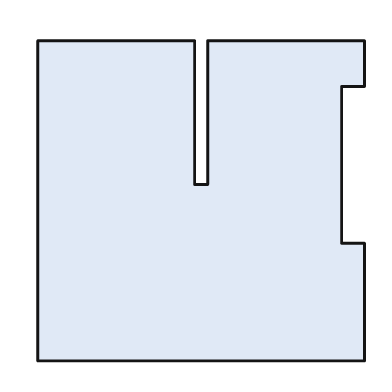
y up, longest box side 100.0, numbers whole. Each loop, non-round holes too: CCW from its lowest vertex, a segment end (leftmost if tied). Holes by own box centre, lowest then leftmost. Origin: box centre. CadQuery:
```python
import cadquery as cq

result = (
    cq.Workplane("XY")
    .moveTo(-50.0, -49.0)
    .lineTo(50.0, -49.0)
    .lineTo(50.0, -13.0)
    .lineTo(43.0, -13.0)
    .lineTo(43.0, 35.0)
    .lineTo(50.0, 35.0)
    .lineTo(50.0, 49.0)
    .lineTo(2.0, 49.0)
    .lineTo(2.0, 5.0)
    .lineTo(-2.0, 5.0)
    .lineTo(-2.0, 49.0)
    .lineTo(-50.0, 49.0)
    .close()
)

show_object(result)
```